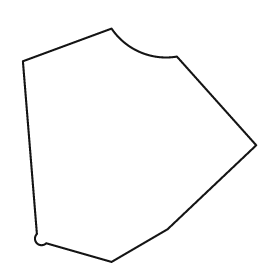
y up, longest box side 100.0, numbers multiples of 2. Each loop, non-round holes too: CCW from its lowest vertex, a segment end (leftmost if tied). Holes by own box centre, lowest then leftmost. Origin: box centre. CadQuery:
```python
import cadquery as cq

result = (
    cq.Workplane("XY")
    .moveTo(-12.0, -50.0)
    .lineTo(12.0, -36.0)
    .lineTo(50.0, 0.0)
    .lineTo(16.0, 38.0)
    .threePointArc((0.0, 40.0), (-12.0, 50.0))
    .lineTo(-50.0, 36.0)
    .lineTo(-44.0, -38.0)
    .threePointArc((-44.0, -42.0), (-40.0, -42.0))
    .close()
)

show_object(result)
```